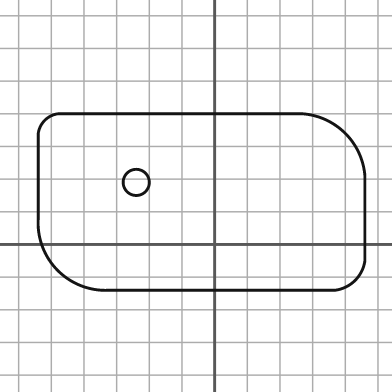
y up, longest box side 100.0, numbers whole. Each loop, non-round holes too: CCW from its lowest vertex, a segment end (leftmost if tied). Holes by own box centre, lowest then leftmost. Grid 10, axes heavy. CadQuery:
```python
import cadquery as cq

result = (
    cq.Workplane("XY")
    .moveTo(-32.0, -14.0)
    .lineTo(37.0, -14.0)
    .threePointArc((43.0, -11.0), (46.0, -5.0))
    .lineTo(46.0, 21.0)
    .threePointArc((40.0, 34.0), (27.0, 40.0))
    .lineTo(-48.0, 40.0)
    .threePointArc((-52.0, 38.0), (-54.0, 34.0))
    .lineTo(-54.0, 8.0)
    .threePointArc((-48.0, -8.0), (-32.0, -14.0))
    .close()
    .moveTo(-24.0, 19.0)
    .circle(4.0)
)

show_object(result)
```